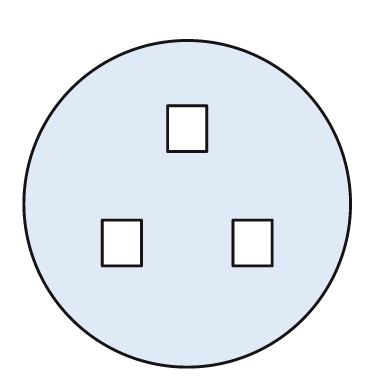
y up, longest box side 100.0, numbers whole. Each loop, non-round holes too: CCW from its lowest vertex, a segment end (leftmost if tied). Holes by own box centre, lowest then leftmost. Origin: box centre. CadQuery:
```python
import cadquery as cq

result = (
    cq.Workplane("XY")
    .moveTo(0.0, 0.0)
    .circle(50.0)
    .moveTo(-26.0, -19.0)
    .lineTo(-14.0, -19.0)
    .lineTo(-14.0, -5.0)
    .lineTo(-26.0, -5.0)
    .close()
    .moveTo(14.0, -19.0)
    .lineTo(26.0, -19.0)
    .lineTo(26.0, -5.0)
    .lineTo(14.0, -5.0)
    .close()
    .moveTo(-6.0, 16.0)
    .lineTo(6.0, 16.0)
    .lineTo(6.0, 30.0)
    .lineTo(-6.0, 30.0)
    .close()
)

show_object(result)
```